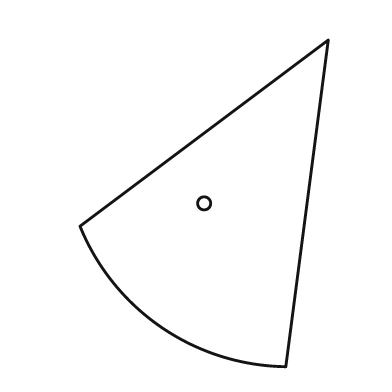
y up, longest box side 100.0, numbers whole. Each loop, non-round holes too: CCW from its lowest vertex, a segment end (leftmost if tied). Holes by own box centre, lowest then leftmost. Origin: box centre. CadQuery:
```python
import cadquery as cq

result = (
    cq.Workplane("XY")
    .moveTo(25.0, -50.0)
    .lineTo(38.0, 50.0)
    .lineTo(-38.0, -7.0)
    .threePointArc((-13.0, -38.0), (25.0, -50.0))
    .close()
    .moveTo(0.0, 0.0)
    .circle(2.0)
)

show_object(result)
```